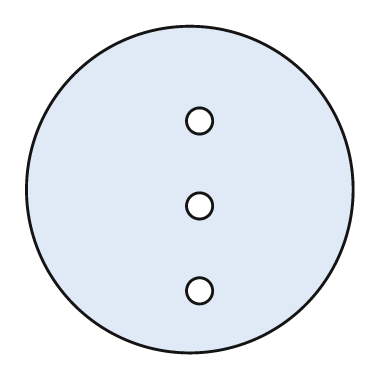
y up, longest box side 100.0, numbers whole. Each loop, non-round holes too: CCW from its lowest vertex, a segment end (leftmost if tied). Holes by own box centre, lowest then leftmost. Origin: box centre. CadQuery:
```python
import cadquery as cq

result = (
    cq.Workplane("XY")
    .moveTo(0.0, 0.0)
    .circle(50.0)
    .moveTo(3.0, -31.0)
    .circle(4.0)
    .moveTo(3.0, -5.0)
    .circle(4.0)
    .moveTo(3.0, 21.0)
    .circle(4.0)
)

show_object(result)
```